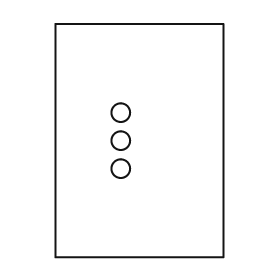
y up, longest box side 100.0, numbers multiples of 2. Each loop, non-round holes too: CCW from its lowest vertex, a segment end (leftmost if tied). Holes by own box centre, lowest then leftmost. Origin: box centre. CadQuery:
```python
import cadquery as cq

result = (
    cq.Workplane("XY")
    .moveTo(-36.0, -50.0)
    .lineTo(36.0, -50.0)
    .lineTo(36.0, 50.0)
    .lineTo(-36.0, 50.0)
    .close()
    .moveTo(-8.0, -12.0)
    .circle(4.0)
    .moveTo(-8.0, 0.0)
    .circle(4.0)
    .moveTo(-8.0, 12.0)
    .circle(4.0)
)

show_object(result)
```